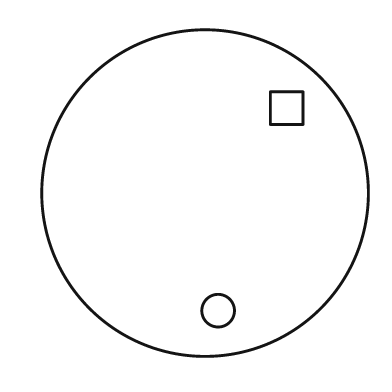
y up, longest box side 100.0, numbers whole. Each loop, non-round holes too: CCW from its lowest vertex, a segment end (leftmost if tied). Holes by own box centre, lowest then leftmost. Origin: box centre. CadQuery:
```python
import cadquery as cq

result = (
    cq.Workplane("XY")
    .moveTo(0.0, 0.0)
    .circle(50.0)
    .moveTo(4.0, -36.0)
    .circle(5.0)
    .moveTo(20.0, 21.0)
    .lineTo(30.0, 21.0)
    .lineTo(30.0, 31.0)
    .lineTo(20.0, 31.0)
    .close()
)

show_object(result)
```